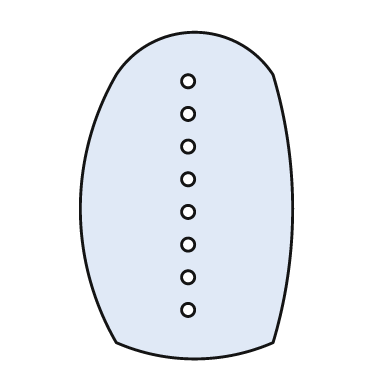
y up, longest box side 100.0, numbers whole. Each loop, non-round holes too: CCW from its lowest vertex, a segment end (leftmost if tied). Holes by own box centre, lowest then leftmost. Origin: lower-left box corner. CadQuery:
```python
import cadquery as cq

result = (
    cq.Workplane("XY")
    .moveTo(11.0, 5.0)
    .threePointArc((35.0, 0.0), (59.0, 5.0))
    .threePointArc((65.0, 46.0), (59.0, 87.0))
    .threePointArc((35.0, 100.0), (11.0, 87.0))
    .threePointArc((0.0, 46.0), (11.0, 5.0))
    .close()
    .moveTo(33.0, 15.0)
    .circle(2.0)
    .moveTo(33.0, 25.0)
    .circle(2.0)
    .moveTo(33.0, 35.0)
    .circle(2.0)
    .moveTo(33.0, 45.0)
    .circle(2.0)
    .moveTo(33.0, 55.0)
    .circle(2.0)
    .moveTo(33.0, 65.0)
    .circle(2.0)
    .moveTo(33.0, 75.0)
    .circle(2.0)
    .moveTo(33.0, 85.0)
    .circle(2.0)
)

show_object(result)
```